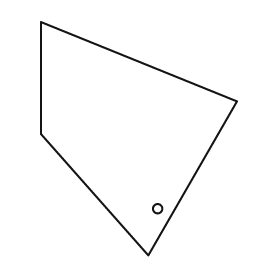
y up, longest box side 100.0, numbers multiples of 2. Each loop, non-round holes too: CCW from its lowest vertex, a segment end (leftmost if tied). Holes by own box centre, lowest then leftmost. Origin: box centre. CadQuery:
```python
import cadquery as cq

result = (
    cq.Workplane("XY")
    .moveTo(4.0, -50.0)
    .lineTo(42.0, 16.0)
    .lineTo(-42.0, 50.0)
    .lineTo(-42.0, 2.0)
    .close()
    .moveTo(8.0, -30.0)
    .circle(2.0)
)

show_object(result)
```